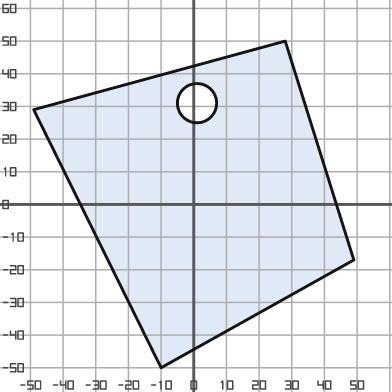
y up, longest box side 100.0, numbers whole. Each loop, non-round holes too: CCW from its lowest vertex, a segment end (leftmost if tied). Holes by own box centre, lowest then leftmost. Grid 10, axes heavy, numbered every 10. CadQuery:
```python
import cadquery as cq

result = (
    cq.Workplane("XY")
    .moveTo(-10.0, -50.0)
    .lineTo(49.0, -17.0)
    .lineTo(28.0, 50.0)
    .lineTo(-49.0, 29.0)
    .close()
    .moveTo(1.0, 31.0)
    .circle(6.0)
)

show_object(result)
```